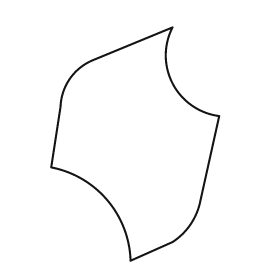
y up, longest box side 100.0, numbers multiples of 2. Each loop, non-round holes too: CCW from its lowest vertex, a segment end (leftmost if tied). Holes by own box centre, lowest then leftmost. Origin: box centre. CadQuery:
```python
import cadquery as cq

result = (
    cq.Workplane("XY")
    .moveTo(-2.0, -50.0)
    .lineTo(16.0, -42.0)
    .threePointArc((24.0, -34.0), (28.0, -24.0))
    .lineTo(36.0, 12.0)
    .threePointArc((16.0, 26.0), (16.0, 50.0))
    .lineTo(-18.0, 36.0)
    .threePointArc((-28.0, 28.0), (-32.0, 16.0))
    .lineTo(-36.0, -10.0)
    .threePointArc((-12.0, -24.0), (-2.0, -50.0))
    .close()
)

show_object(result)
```